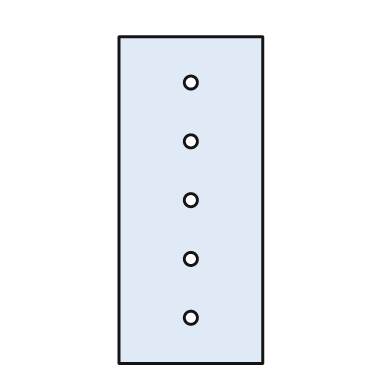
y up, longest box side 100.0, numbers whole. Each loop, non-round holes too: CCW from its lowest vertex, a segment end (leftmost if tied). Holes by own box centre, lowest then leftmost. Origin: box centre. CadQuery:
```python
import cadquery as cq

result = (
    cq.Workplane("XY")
    .moveTo(-22.0, -50.0)
    .lineTo(22.0, -50.0)
    .lineTo(22.0, 50.0)
    .lineTo(-22.0, 50.0)
    .close()
    .moveTo(0.0, -36.0)
    .circle(2.0)
    .moveTo(0.0, -18.0)
    .circle(2.0)
    .moveTo(0.0, 0.0)
    .circle(2.0)
    .moveTo(0.0, 18.0)
    .circle(2.0)
    .moveTo(0.0, 36.0)
    .circle(2.0)
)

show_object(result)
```